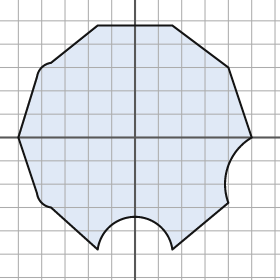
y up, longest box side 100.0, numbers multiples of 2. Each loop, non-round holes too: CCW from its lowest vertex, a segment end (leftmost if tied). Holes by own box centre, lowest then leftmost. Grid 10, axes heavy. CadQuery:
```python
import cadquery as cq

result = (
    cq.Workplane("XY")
    .moveTo(-16.0, -48.0)
    .threePointArc((0.0, -34.0), (16.0, -48.0))
    .lineTo(40.0, -28.0)
    .threePointArc((40.0, -12.0), (50.0, 0.0))
    .lineTo(40.0, 30.0)
    .lineTo(16.0, 48.0)
    .lineTo(-16.0, 48.0)
    .lineTo(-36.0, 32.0)
    .threePointArc((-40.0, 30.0), (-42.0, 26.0))
    .lineTo(-50.0, 0.0)
    .lineTo(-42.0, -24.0)
    .threePointArc((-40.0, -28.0), (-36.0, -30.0))
    .close()
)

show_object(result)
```